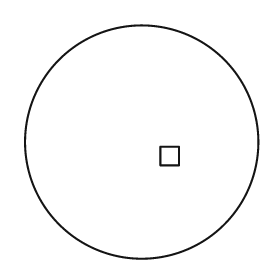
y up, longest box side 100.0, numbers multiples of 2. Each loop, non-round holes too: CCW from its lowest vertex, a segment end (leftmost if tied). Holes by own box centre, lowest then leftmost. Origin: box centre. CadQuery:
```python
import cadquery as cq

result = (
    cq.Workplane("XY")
    .moveTo(0.0, 0.0)
    .circle(50.0)
    .moveTo(8.0, -10.0)
    .lineTo(16.0, -10.0)
    .lineTo(16.0, -2.0)
    .lineTo(8.0, -2.0)
    .close()
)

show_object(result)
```